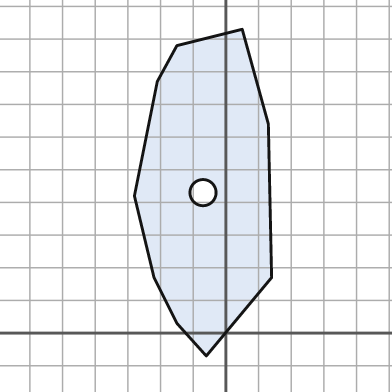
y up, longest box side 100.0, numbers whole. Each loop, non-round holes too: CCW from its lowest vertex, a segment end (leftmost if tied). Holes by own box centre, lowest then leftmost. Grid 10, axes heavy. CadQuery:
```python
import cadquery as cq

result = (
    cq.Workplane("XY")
    .moveTo(-6.0, -7.0)
    .lineTo(14.0, 17.0)
    .lineTo(13.0, 64.0)
    .lineTo(5.0, 93.0)
    .lineTo(-15.0, 88.0)
    .lineTo(-21.0, 77.0)
    .lineTo(-28.0, 42.0)
    .lineTo(-22.0, 17.0)
    .lineTo(-15.0, 3.0)
    .close()
    .moveTo(-7.0, 43.0)
    .circle(4.0)
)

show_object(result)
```